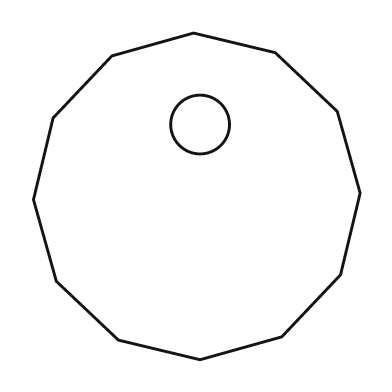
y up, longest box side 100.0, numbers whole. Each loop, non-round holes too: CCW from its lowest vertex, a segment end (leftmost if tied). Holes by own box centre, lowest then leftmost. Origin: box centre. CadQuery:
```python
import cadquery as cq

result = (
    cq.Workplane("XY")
    .moveTo(1.0, -50.0)
    .lineTo(26.0, -43.0)
    .lineTo(44.0, -24.0)
    .lineTo(50.0, 1.0)
    .lineTo(43.0, 26.0)
    .lineTo(24.0, 44.0)
    .lineTo(-1.0, 50.0)
    .lineTo(-26.0, 43.0)
    .lineTo(-44.0, 24.0)
    .lineTo(-50.0, -1.0)
    .lineTo(-43.0, -26.0)
    .lineTo(-24.0, -44.0)
    .close()
    .moveTo(1.0, 22.0)
    .circle(9.0)
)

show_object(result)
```